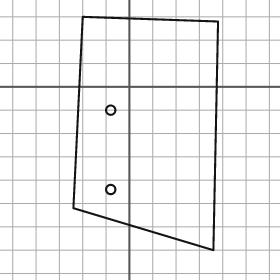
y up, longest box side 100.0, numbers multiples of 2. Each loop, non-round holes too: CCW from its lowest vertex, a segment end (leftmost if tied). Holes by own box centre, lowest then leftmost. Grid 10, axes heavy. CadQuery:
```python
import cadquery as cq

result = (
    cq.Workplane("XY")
    .moveTo(36.0, -70.0)
    .lineTo(38.0, 28.0)
    .lineTo(-20.0, 30.0)
    .lineTo(-24.0, -52.0)
    .close()
    .moveTo(-8.0, -44.0)
    .circle(2.0)
    .moveTo(-8.0, -10.0)
    .circle(2.0)
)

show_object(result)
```